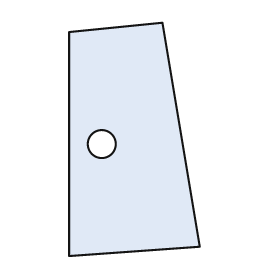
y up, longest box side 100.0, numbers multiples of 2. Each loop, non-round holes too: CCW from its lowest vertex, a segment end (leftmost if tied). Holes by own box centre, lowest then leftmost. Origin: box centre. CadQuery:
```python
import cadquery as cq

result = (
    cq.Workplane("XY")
    .moveTo(-28.0, -50.0)
    .lineTo(28.0, -46.0)
    .lineTo(12.0, 50.0)
    .lineTo(-28.0, 46.0)
    .close()
    .moveTo(-14.0, -2.0)
    .circle(6.0)
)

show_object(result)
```